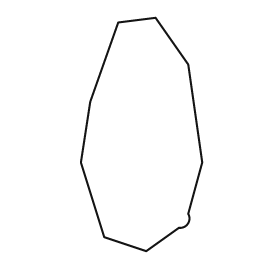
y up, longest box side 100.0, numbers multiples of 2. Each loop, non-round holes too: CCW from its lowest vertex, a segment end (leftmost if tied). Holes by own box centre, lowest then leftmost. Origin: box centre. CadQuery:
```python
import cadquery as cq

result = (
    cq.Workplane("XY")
    .moveTo(2.0, -50.0)
    .lineTo(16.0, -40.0)
    .threePointArc((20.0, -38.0), (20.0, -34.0))
    .lineTo(26.0, -12.0)
    .lineTo(20.0, 30.0)
    .lineTo(6.0, 50.0)
    .lineTo(-10.0, 48.0)
    .lineTo(-22.0, 14.0)
    .lineTo(-26.0, -12.0)
    .lineTo(-16.0, -44.0)
    .close()
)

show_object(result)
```